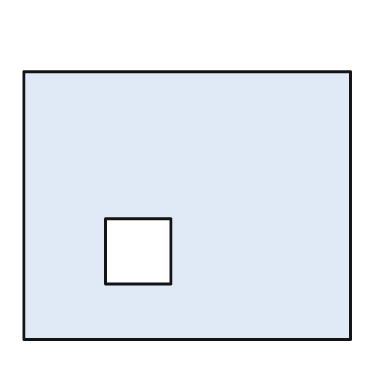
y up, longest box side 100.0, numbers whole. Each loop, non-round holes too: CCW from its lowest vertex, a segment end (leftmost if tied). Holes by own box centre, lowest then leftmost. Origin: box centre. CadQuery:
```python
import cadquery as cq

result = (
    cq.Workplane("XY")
    .moveTo(-50.0, -41.0)
    .lineTo(50.0, -41.0)
    .lineTo(50.0, 41.0)
    .lineTo(-50.0, 41.0)
    .close()
    .moveTo(-25.0, -24.0)
    .lineTo(-5.0, -24.0)
    .lineTo(-5.0, -4.0)
    .lineTo(-25.0, -4.0)
    .close()
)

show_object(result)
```